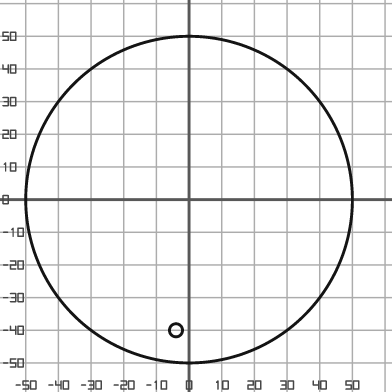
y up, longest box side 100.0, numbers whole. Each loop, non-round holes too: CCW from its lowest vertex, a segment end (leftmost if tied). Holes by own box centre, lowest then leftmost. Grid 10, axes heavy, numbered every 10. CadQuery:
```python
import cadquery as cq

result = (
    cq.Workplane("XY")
    .moveTo(0.0, 0.0)
    .circle(50.0)
    .moveTo(-4.0, -40.0)
    .circle(2.0)
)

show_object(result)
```